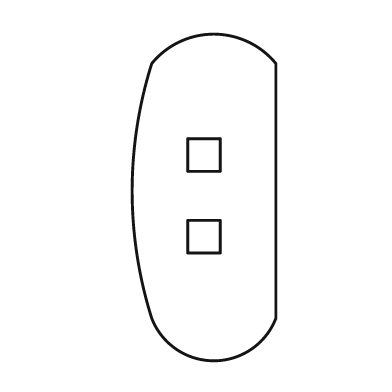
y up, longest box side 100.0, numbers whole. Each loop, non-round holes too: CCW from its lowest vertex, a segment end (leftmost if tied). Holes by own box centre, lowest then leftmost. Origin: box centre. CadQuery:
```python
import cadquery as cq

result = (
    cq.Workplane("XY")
    .moveTo(-16.0, -37.0)
    .threePointArc((3.0, -50.0), (22.0, -37.0))
    .lineTo(22.0, 41.0)
    .threePointArc((3.0, 50.0), (-16.0, 41.0))
    .threePointArc((-22.0, 2.0), (-16.0, -37.0))
    .close()
    .moveTo(-5.0, -17.0)
    .lineTo(5.0, -17.0)
    .lineTo(5.0, -7.0)
    .lineTo(-5.0, -7.0)
    .close()
    .moveTo(-5.0, 8.0)
    .lineTo(5.0, 8.0)
    .lineTo(5.0, 18.0)
    .lineTo(-5.0, 18.0)
    .close()
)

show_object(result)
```